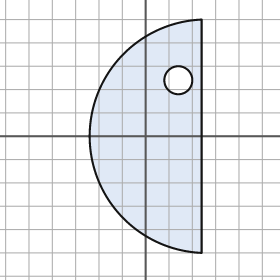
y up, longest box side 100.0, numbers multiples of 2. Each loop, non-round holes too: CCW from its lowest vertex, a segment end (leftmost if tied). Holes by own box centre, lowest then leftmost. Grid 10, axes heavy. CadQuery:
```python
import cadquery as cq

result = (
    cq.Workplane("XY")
    .moveTo(24.0, -50.0)
    .lineTo(24.0, 50.0)
    .threePointArc((-24.0, 0.0), (24.0, -50.0))
    .close()
    .moveTo(14.0, 24.0)
    .circle(6.0)
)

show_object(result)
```